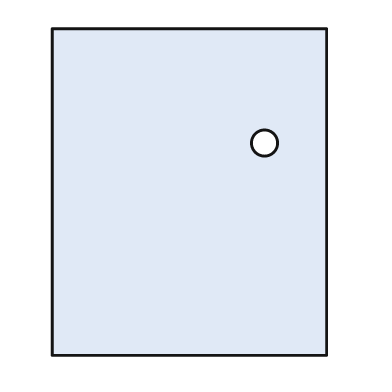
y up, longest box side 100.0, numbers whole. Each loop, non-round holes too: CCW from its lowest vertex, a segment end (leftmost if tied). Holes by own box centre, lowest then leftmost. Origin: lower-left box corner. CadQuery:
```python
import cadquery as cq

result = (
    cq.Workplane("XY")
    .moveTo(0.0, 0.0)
    .lineTo(84.0, 0.0)
    .lineTo(84.0, 100.0)
    .lineTo(0.0, 100.0)
    .close()
    .moveTo(65.0, 65.0)
    .circle(4.0)
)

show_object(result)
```